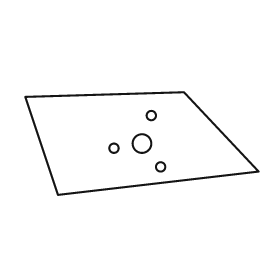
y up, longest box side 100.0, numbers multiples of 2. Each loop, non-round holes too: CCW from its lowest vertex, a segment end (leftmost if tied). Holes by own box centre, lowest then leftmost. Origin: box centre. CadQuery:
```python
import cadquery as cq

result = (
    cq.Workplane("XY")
    .moveTo(-36.0, -22.0)
    .lineTo(50.0, -12.0)
    .lineTo(18.0, 22.0)
    .lineTo(-50.0, 20.0)
    .close()
    .moveTo(8.0, -10.0)
    .circle(2.0)
    .moveTo(-12.0, -2.0)
    .circle(2.0)
    .moveTo(0.0, 0.0)
    .circle(4.0)
    .moveTo(4.0, 12.0)
    .circle(2.0)
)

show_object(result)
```